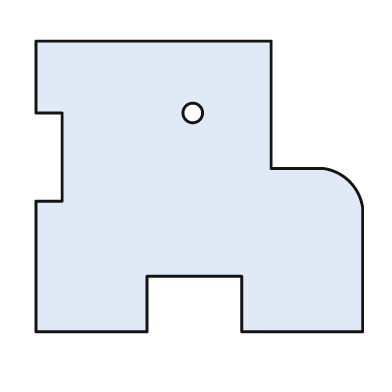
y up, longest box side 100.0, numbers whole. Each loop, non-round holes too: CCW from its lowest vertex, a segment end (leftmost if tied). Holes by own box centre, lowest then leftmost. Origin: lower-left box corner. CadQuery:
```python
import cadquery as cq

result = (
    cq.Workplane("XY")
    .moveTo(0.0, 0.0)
    .lineTo(34.0, 0.0)
    .lineTo(34.0, 17.0)
    .lineTo(63.0, 17.0)
    .lineTo(63.0, 0.0)
    .lineTo(100.0, 0.0)
    .lineTo(100.0, 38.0)
    .threePointArc((96.0, 46.0), (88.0, 50.0))
    .lineTo(72.0, 50.0)
    .lineTo(72.0, 89.0)
    .lineTo(0.0, 89.0)
    .lineTo(0.0, 67.0)
    .lineTo(8.0, 67.0)
    .lineTo(8.0, 40.0)
    .lineTo(0.0, 40.0)
    .close()
    .moveTo(48.0, 67.0)
    .circle(3.0)
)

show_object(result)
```